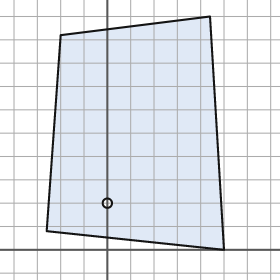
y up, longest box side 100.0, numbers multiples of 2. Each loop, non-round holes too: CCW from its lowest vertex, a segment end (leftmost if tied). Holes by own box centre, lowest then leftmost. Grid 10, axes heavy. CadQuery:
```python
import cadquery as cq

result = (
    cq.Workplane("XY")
    .moveTo(50.0, 0.0)
    .lineTo(44.0, 100.0)
    .lineTo(-20.0, 92.0)
    .lineTo(-26.0, 8.0)
    .close()
    .moveTo(0.0, 20.0)
    .circle(2.0)
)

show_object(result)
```